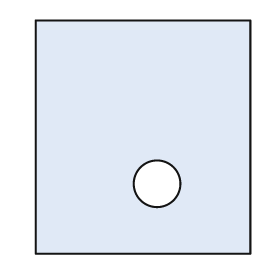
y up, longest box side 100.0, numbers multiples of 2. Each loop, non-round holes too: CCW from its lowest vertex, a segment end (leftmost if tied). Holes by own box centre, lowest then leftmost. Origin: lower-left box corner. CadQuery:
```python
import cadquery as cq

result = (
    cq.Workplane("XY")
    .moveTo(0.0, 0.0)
    .lineTo(92.0, 0.0)
    .lineTo(92.0, 100.0)
    .lineTo(0.0, 100.0)
    .close()
    .moveTo(52.0, 30.0)
    .circle(10.0)
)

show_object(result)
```